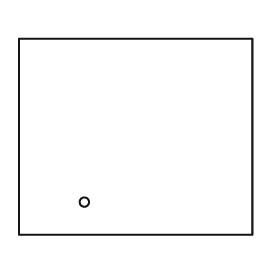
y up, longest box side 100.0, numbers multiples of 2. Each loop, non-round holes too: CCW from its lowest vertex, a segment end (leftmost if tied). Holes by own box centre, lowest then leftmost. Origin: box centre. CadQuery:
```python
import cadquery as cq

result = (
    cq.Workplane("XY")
    .moveTo(-50.0, -42.0)
    .lineTo(50.0, -42.0)
    .lineTo(50.0, 42.0)
    .lineTo(-50.0, 42.0)
    .close()
    .moveTo(-22.0, -28.0)
    .circle(2.0)
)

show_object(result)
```